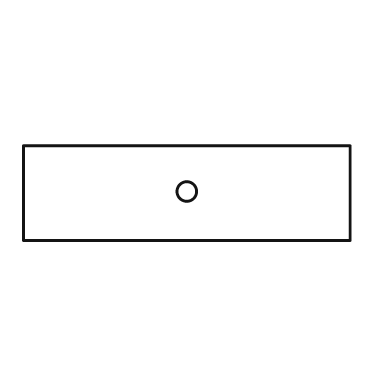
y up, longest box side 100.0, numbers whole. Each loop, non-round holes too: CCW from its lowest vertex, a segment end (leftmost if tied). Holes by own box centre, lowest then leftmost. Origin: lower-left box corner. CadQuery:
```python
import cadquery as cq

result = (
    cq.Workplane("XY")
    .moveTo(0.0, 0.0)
    .lineTo(100.0, 0.0)
    .lineTo(100.0, 29.0)
    .lineTo(0.0, 29.0)
    .close()
    .moveTo(50.0, 15.0)
    .circle(3.0)
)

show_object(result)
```